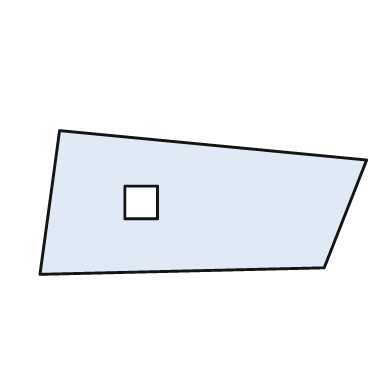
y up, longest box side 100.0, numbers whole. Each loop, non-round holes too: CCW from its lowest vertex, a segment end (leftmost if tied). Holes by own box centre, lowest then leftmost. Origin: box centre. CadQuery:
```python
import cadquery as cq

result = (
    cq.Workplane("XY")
    .moveTo(-50.0, -22.0)
    .lineTo(37.0, -20.0)
    .lineTo(50.0, 13.0)
    .lineTo(-44.0, 22.0)
    .close()
    .moveTo(-24.0, -5.0)
    .lineTo(-14.0, -5.0)
    .lineTo(-14.0, 5.0)
    .lineTo(-24.0, 5.0)
    .close()
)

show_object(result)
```